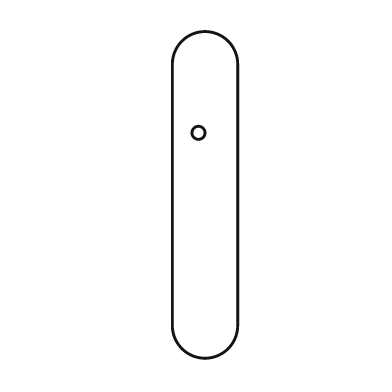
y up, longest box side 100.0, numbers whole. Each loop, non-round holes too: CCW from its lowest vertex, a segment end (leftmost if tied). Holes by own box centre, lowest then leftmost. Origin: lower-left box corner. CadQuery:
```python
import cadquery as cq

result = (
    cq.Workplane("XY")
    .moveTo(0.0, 10.0)
    .threePointArc((10.0, 0.0), (20.0, 10.0))
    .lineTo(20.0, 90.0)
    .threePointArc((10.0, 100.0), (0.0, 90.0))
    .close()
    .moveTo(8.0, 69.0)
    .circle(2.0)
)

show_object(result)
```